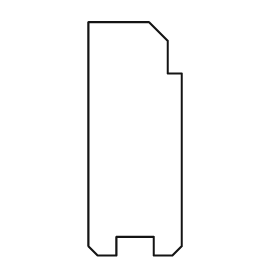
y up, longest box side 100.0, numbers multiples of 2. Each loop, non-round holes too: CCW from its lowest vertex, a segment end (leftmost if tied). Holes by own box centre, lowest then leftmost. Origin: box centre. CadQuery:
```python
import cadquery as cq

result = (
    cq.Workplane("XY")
    .moveTo(-16.0, -50.0)
    .lineTo(-8.0, -50.0)
    .lineTo(-8.0, -42.0)
    .lineTo(8.0, -42.0)
    .lineTo(8.0, -50.0)
    .lineTo(16.0, -50.0)
    .lineTo(20.0, -46.0)
    .lineTo(20.0, 28.0)
    .lineTo(14.0, 28.0)
    .lineTo(14.0, 42.0)
    .lineTo(6.0, 50.0)
    .lineTo(-20.0, 50.0)
    .lineTo(-20.0, -46.0)
    .close()
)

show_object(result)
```